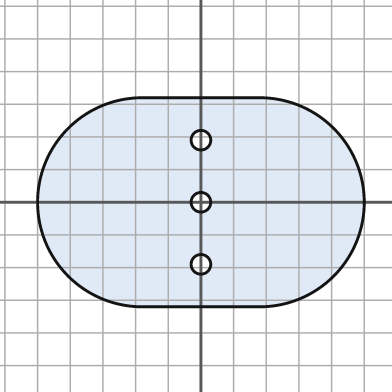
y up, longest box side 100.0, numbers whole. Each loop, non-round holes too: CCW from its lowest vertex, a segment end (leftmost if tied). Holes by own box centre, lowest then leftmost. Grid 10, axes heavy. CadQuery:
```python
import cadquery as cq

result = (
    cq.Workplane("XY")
    .moveTo(-18.0, -32.0)
    .lineTo(18.0, -32.0)
    .threePointArc((50.0, 0.0), (18.0, 32.0))
    .lineTo(-18.0, 32.0)
    .threePointArc((-50.0, 0.0), (-18.0, -32.0))
    .close()
    .moveTo(0.0, -19.0)
    .circle(3.0)
    .moveTo(0.0, 0.0)
    .circle(3.0)
    .moveTo(0.0, 19.0)
    .circle(3.0)
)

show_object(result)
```